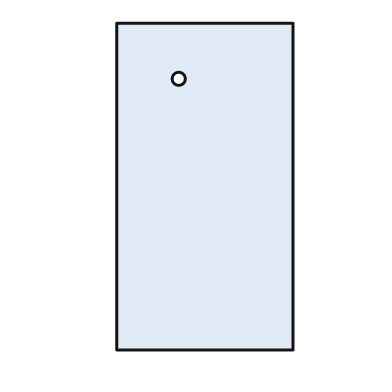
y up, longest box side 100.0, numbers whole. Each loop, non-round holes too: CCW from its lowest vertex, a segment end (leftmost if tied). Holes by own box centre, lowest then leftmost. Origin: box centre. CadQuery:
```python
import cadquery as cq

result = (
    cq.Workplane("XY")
    .moveTo(-27.0, -50.0)
    .lineTo(27.0, -50.0)
    .lineTo(27.0, 50.0)
    .lineTo(-27.0, 50.0)
    .close()
    .moveTo(-8.0, 33.0)
    .circle(2.0)
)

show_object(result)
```